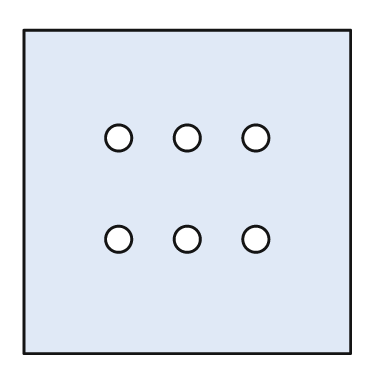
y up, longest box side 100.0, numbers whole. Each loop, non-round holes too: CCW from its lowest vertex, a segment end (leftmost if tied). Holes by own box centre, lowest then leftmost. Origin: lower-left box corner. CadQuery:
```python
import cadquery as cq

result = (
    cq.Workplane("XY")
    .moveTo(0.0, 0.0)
    .lineTo(100.0, 0.0)
    .lineTo(100.0, 99.0)
    .lineTo(0.0, 99.0)
    .close()
    .moveTo(29.0, 35.0)
    .circle(4.0)
    .moveTo(50.0, 35.0)
    .circle(4.0)
    .moveTo(71.0, 35.0)
    .circle(4.0)
    .moveTo(29.0, 66.0)
    .circle(4.0)
    .moveTo(50.0, 66.0)
    .circle(4.0)
    .moveTo(71.0, 66.0)
    .circle(4.0)
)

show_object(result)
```